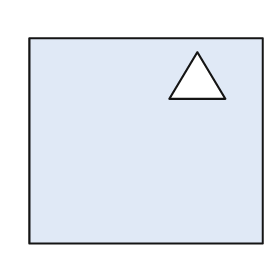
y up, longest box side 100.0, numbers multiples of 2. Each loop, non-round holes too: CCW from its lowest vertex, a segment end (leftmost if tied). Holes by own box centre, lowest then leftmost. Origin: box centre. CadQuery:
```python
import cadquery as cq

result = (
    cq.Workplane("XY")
    .moveTo(-50.0, -44.0)
    .lineTo(50.0, -44.0)
    .lineTo(50.0, 44.0)
    .lineTo(-50.0, 44.0)
    .close()
    .moveTo(10.0, 18.0)
    .lineTo(34.0, 18.0)
    .lineTo(22.0, 38.0)
    .close()
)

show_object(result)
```